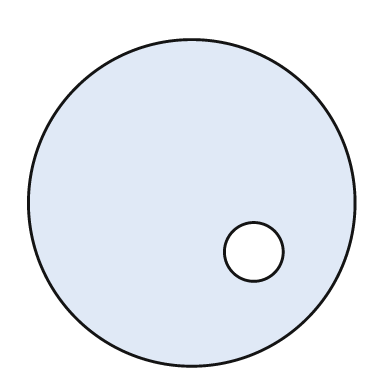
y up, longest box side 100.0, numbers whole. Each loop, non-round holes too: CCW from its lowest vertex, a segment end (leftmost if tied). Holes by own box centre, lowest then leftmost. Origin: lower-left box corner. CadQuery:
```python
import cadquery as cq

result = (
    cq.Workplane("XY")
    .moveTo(50.0, 50.0)
    .circle(50.0)
    .moveTo(69.0, 35.0)
    .circle(9.0)
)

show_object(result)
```